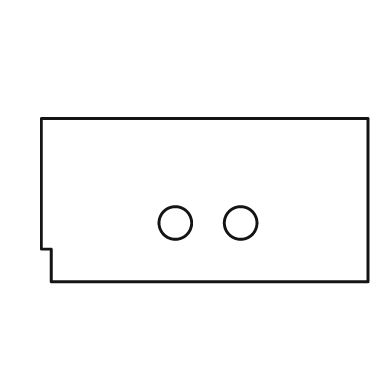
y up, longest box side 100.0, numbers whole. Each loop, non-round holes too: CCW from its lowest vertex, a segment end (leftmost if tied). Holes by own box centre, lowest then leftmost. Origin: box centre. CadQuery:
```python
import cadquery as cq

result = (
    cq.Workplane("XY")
    .moveTo(-47.0, -25.0)
    .lineTo(50.0, -25.0)
    .lineTo(50.0, 25.0)
    .lineTo(-50.0, 25.0)
    .lineTo(-50.0, -15.0)
    .lineTo(-47.0, -15.0)
    .close()
    .moveTo(-9.0, -7.0)
    .circle(5.0)
    .moveTo(11.0, -7.0)
    .circle(5.0)
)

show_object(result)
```